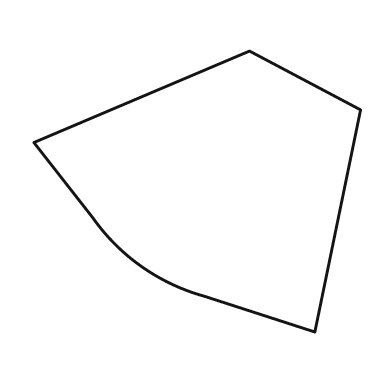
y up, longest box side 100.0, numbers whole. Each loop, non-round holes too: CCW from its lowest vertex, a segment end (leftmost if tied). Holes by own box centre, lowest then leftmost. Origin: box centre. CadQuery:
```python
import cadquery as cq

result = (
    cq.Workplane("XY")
    .moveTo(36.0, -43.0)
    .lineTo(50.0, 25.0)
    .lineTo(16.0, 43.0)
    .lineTo(-50.0, 15.0)
    .lineTo(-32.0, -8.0)
    .threePointArc((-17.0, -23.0), (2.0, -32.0))
    .close()
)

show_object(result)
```